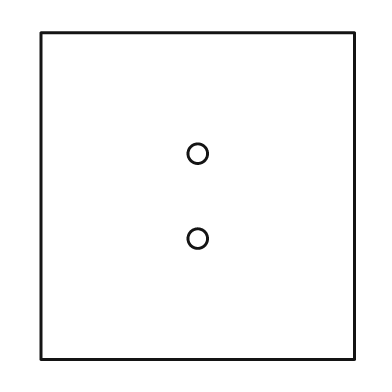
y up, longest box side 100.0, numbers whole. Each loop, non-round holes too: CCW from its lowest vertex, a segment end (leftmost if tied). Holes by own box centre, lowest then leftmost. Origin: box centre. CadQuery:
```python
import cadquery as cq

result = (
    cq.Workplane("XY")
    .moveTo(-48.0, -50.0)
    .lineTo(48.0, -50.0)
    .lineTo(48.0, 50.0)
    .lineTo(-48.0, 50.0)
    .close()
    .moveTo(0.0, -13.0)
    .circle(3.0)
    .moveTo(0.0, 13.0)
    .circle(3.0)
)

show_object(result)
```